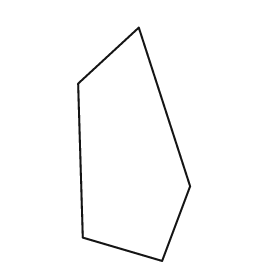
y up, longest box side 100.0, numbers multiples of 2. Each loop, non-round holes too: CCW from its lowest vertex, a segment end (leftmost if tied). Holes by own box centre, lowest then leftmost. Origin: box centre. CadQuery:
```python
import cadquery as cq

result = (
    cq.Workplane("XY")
    .moveTo(12.0, -50.0)
    .lineTo(24.0, -18.0)
    .lineTo(2.0, 50.0)
    .lineTo(-24.0, 26.0)
    .lineTo(-22.0, -40.0)
    .close()
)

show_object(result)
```